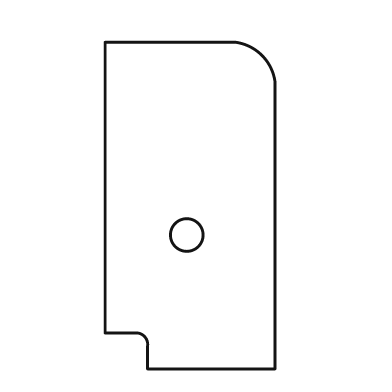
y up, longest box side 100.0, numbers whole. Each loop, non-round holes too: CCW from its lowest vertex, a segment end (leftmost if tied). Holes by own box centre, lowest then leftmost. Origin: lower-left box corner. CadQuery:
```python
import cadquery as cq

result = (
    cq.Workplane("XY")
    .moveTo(13.0, 0.0)
    .lineTo(52.0, 0.0)
    .lineTo(52.0, 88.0)
    .threePointArc((48.0, 96.0), (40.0, 100.0))
    .lineTo(0.0, 100.0)
    .lineTo(0.0, 11.0)
    .lineTo(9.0, 11.0)
    .threePointArc((12.0, 10.0), (13.0, 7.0))
    .close()
    .moveTo(25.0, 41.0)
    .circle(5.0)
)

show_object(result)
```